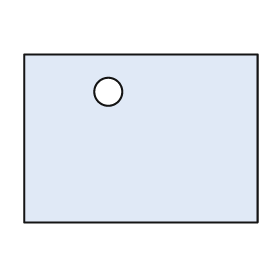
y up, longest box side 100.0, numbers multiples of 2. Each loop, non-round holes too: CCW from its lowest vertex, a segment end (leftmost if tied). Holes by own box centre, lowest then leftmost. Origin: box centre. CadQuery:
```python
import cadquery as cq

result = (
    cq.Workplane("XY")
    .moveTo(-50.0, -36.0)
    .lineTo(50.0, -36.0)
    .lineTo(50.0, 36.0)
    .lineTo(-50.0, 36.0)
    .close()
    .moveTo(-14.0, 20.0)
    .circle(6.0)
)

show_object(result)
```